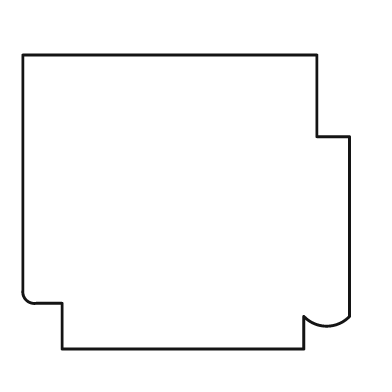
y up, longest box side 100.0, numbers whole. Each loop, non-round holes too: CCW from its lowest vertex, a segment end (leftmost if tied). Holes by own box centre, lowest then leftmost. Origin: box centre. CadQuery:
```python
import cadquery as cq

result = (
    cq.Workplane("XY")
    .moveTo(-38.0, -45.0)
    .lineTo(36.0, -45.0)
    .lineTo(36.0, -35.0)
    .threePointArc((43.0, -38.0), (50.0, -35.0))
    .lineTo(50.0, 20.0)
    .lineTo(40.0, 20.0)
    .lineTo(40.0, 45.0)
    .lineTo(-50.0, 45.0)
    .lineTo(-50.0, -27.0)
    .threePointArc((-49.0, -30.0), (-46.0, -31.0))
    .lineTo(-38.0, -31.0)
    .close()
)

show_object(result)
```